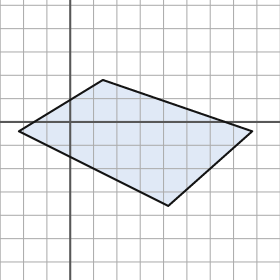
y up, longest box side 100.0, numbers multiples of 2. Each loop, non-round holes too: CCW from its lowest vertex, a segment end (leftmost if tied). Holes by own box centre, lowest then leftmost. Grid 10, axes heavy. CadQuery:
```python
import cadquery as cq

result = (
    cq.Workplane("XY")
    .moveTo(42.0, -36.0)
    .lineTo(78.0, -4.0)
    .lineTo(14.0, 18.0)
    .lineTo(-22.0, -4.0)
    .close()
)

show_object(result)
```